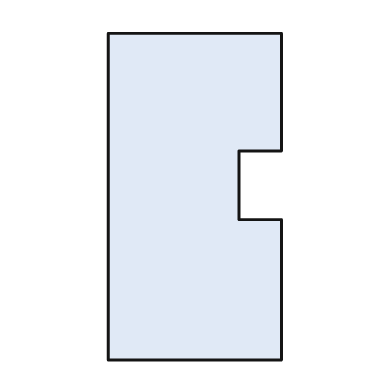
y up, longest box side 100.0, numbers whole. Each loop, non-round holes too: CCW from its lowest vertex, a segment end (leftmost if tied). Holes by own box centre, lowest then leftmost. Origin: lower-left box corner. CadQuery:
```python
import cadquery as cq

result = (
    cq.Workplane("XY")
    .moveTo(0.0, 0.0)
    .lineTo(53.0, 0.0)
    .lineTo(53.0, 43.0)
    .lineTo(40.0, 43.0)
    .lineTo(40.0, 64.0)
    .lineTo(53.0, 64.0)
    .lineTo(53.0, 100.0)
    .lineTo(0.0, 100.0)
    .close()
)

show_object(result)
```